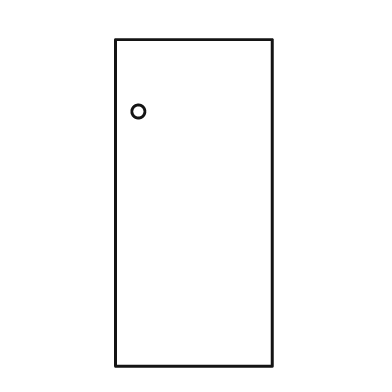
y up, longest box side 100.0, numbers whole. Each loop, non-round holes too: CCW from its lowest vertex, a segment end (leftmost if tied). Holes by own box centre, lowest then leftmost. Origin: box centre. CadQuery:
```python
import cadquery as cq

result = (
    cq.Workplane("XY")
    .moveTo(-24.0, -50.0)
    .lineTo(24.0, -50.0)
    .lineTo(24.0, 50.0)
    .lineTo(-24.0, 50.0)
    .close()
    .moveTo(-17.0, 28.0)
    .circle(2.0)
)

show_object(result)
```